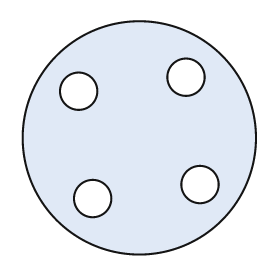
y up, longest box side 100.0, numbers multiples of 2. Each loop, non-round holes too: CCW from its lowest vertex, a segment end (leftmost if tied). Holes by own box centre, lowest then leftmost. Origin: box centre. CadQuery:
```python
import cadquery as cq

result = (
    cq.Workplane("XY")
    .moveTo(0.0, 0.0)
    .circle(50.0)
    .moveTo(-20.0, -26.0)
    .circle(8.0)
    .moveTo(26.0, -20.0)
    .circle(8.0)
    .moveTo(-26.0, 20.0)
    .circle(8.0)
    .moveTo(20.0, 26.0)
    .circle(8.0)
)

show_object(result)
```